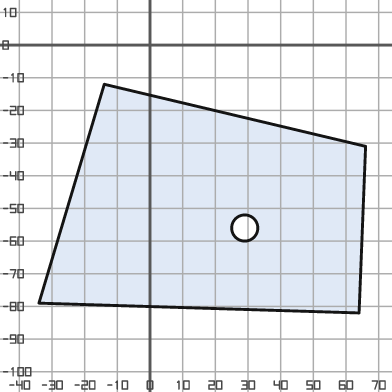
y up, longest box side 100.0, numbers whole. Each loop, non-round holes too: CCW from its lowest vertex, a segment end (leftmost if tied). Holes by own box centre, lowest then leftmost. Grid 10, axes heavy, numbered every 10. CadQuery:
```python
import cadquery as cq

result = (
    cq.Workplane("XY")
    .moveTo(64.0, -82.0)
    .lineTo(66.0, -31.0)
    .lineTo(-14.0, -12.0)
    .lineTo(-34.0, -79.0)
    .close()
    .moveTo(29.0, -56.0)
    .circle(4.0)
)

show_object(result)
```